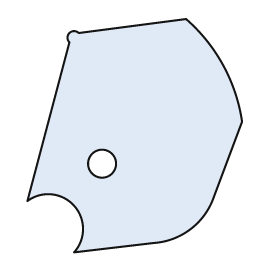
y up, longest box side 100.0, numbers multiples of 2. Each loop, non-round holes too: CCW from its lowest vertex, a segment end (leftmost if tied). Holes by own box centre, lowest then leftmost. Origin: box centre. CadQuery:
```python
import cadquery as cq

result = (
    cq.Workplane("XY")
    .moveTo(-26.0, -50.0)
    .lineTo(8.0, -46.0)
    .threePointArc((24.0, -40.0), (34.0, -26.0))
    .lineTo(46.0, 6.0)
    .threePointArc((38.0, 30.0), (22.0, 50.0))
    .lineTo(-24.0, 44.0)
    .threePointArc((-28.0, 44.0), (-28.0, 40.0))
    .lineTo(-46.0, -28.0)
    .threePointArc((-26.0, -30.0), (-26.0, -50.0))
    .close()
    .moveTo(-14.0, -12.0)
    .circle(6.0)
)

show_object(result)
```